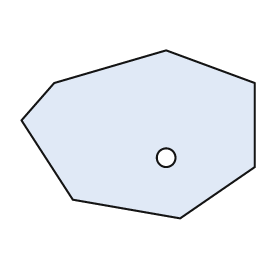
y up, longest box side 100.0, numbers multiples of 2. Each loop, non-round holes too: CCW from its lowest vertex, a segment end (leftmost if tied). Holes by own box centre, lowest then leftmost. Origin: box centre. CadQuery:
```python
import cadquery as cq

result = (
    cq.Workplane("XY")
    .moveTo(18.0, -36.0)
    .lineTo(50.0, -14.0)
    .lineTo(50.0, 22.0)
    .lineTo(12.0, 36.0)
    .lineTo(-36.0, 22.0)
    .lineTo(-50.0, 6.0)
    .lineTo(-28.0, -28.0)
    .close()
    .moveTo(12.0, -10.0)
    .circle(4.0)
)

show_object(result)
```